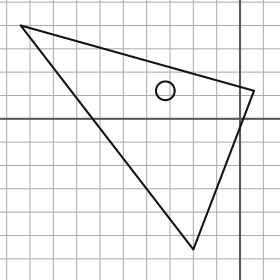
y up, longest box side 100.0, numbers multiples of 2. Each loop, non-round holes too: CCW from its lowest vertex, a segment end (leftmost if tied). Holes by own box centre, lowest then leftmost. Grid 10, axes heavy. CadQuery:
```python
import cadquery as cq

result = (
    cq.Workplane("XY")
    .moveTo(-20.0, -56.0)
    .lineTo(6.0, 12.0)
    .lineTo(-94.0, 40.0)
    .close()
    .moveTo(-32.0, 12.0)
    .circle(4.0)
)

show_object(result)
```